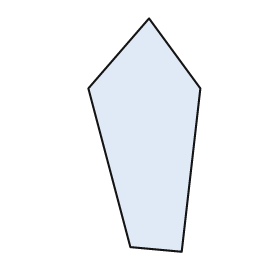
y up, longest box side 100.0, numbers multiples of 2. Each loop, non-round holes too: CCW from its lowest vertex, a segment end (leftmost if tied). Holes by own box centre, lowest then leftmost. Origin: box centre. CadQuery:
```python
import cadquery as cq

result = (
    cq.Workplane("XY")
    .moveTo(16.0, -50.0)
    .lineTo(24.0, 20.0)
    .lineTo(2.0, 50.0)
    .lineTo(-24.0, 20.0)
    .lineTo(-6.0, -48.0)
    .close()
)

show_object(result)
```